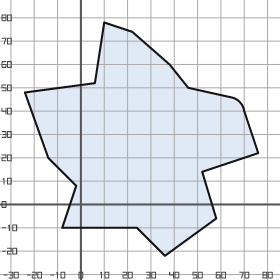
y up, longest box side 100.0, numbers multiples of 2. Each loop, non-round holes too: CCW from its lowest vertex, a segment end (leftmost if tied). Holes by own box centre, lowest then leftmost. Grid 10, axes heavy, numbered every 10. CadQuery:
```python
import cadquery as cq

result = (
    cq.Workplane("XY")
    .moveTo(36.0, -22.0)
    .lineTo(58.0, -6.0)
    .lineTo(52.0, 14.0)
    .lineTo(76.0, 22.0)
    .lineTo(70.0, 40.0)
    .threePointArc((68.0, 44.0), (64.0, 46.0))
    .lineTo(46.0, 50.0)
    .lineTo(38.0, 60.0)
    .lineTo(22.0, 74.0)
    .lineTo(10.0, 78.0)
    .lineTo(6.0, 52.0)
    .lineTo(-24.0, 48.0)
    .lineTo(-14.0, 20.0)
    .lineTo(-2.0, 8.0)
    .lineTo(-8.0, -10.0)
    .lineTo(24.0, -10.0)
    .close()
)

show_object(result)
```